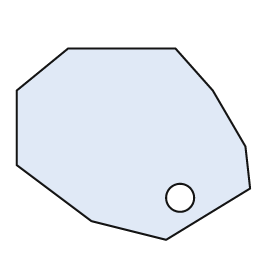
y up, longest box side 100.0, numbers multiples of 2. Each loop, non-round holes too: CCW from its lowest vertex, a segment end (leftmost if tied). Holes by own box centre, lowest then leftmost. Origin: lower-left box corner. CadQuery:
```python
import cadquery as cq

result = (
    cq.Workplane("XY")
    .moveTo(64.0, 0.0)
    .lineTo(100.0, 22.0)
    .lineTo(98.0, 40.0)
    .lineTo(84.0, 64.0)
    .lineTo(68.0, 82.0)
    .lineTo(22.0, 82.0)
    .lineTo(0.0, 64.0)
    .lineTo(0.0, 32.0)
    .lineTo(32.0, 8.0)
    .close()
    .moveTo(70.0, 18.0)
    .circle(6.0)
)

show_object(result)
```